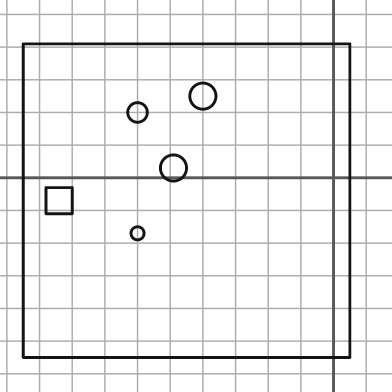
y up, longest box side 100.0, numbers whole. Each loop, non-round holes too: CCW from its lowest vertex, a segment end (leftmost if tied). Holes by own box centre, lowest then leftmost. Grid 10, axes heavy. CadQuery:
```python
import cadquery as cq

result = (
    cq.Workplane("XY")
    .moveTo(-95.0, -55.0)
    .lineTo(5.0, -55.0)
    .lineTo(5.0, 41.0)
    .lineTo(-95.0, 41.0)
    .close()
    .moveTo(-60.0, -17.0)
    .circle(2.0)
    .moveTo(-88.0, -11.0)
    .lineTo(-80.0, -11.0)
    .lineTo(-80.0, -3.0)
    .lineTo(-88.0, -3.0)
    .close()
    .moveTo(-49.0, 3.0)
    .circle(4.0)
    .moveTo(-60.0, 20.0)
    .circle(3.0)
    .moveTo(-40.0, 25.0)
    .circle(4.0)
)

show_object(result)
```